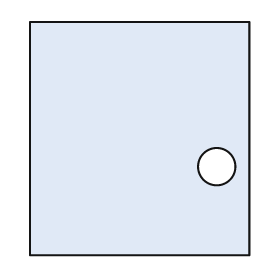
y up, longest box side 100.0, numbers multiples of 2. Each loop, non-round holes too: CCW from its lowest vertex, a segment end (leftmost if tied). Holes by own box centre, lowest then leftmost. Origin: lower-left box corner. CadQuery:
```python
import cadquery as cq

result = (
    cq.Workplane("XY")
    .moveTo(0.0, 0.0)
    .lineTo(94.0, 0.0)
    .lineTo(94.0, 100.0)
    .lineTo(0.0, 100.0)
    .close()
    .moveTo(80.0, 38.0)
    .circle(8.0)
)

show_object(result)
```